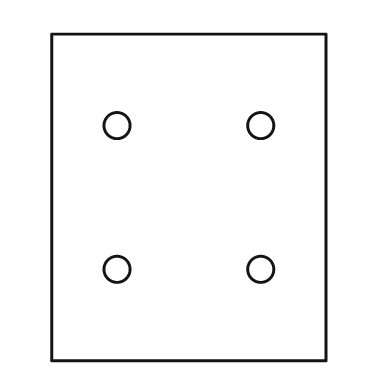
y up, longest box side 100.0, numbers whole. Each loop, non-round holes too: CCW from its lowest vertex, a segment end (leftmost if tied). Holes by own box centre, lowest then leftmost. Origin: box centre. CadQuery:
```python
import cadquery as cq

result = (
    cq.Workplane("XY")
    .moveTo(-42.0, -50.0)
    .lineTo(42.0, -50.0)
    .lineTo(42.0, 50.0)
    .lineTo(-42.0, 50.0)
    .close()
    .moveTo(-22.0, -22.0)
    .circle(4.0)
    .moveTo(22.0, -22.0)
    .circle(4.0)
    .moveTo(-22.0, 22.0)
    .circle(4.0)
    .moveTo(22.0, 22.0)
    .circle(4.0)
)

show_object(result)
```